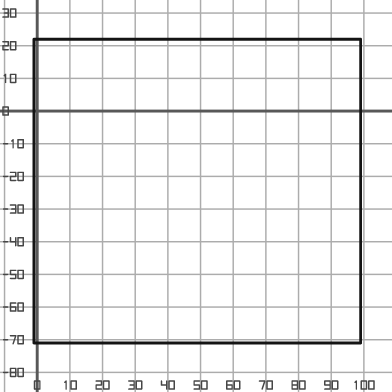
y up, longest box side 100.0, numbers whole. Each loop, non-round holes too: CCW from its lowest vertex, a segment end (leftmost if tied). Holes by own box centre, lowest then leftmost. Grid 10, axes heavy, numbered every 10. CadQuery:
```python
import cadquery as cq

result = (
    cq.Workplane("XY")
    .moveTo(-1.0, -71.0)
    .lineTo(99.0, -71.0)
    .lineTo(99.0, 22.0)
    .lineTo(-1.0, 22.0)
    .close()
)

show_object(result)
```